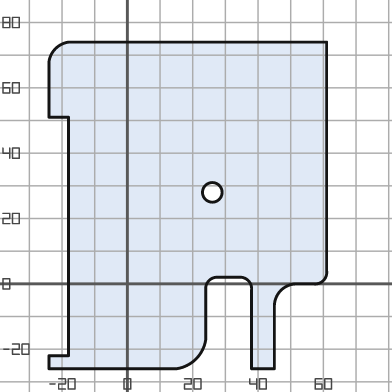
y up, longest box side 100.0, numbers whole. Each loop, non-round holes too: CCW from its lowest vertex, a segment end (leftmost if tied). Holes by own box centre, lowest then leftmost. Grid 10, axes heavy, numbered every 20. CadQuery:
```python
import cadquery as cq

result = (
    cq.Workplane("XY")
    .moveTo(-24.0, -26.0)
    .lineTo(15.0, -26.0)
    .threePointArc((21.0, -23.0), (24.0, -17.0))
    .lineTo(24.0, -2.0)
    .threePointArc((25.0, 1.0), (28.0, 2.0))
    .lineTo(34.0, 2.0)
    .threePointArc((37.0, 1.0), (38.0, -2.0))
    .lineTo(38.0, -26.0)
    .lineTo(45.0, -26.0)
    .lineTo(45.0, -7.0)
    .threePointArc((47.0, -2.0), (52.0, 0.0))
    .lineTo(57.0, 0.0)
    .threePointArc((60.0, 1.0), (61.0, 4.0))
    .lineTo(61.0, 74.0)
    .lineTo(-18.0, 74.0)
    .threePointArc((-22.0, 72.0), (-24.0, 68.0))
    .lineTo(-24.0, 51.0)
    .lineTo(-18.0, 51.0)
    .lineTo(-18.0, -22.0)
    .lineTo(-24.0, -22.0)
    .close()
    .moveTo(26.0, 28.0)
    .circle(3.0)
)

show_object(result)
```